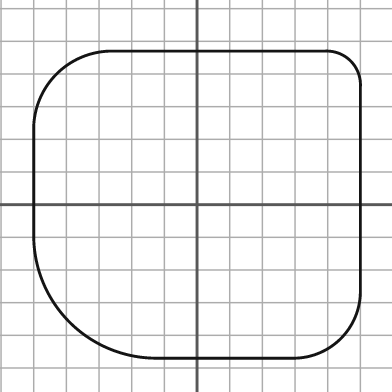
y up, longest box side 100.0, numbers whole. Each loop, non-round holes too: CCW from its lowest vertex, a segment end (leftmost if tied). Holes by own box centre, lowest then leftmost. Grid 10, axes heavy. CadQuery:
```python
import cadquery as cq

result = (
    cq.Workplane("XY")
    .moveTo(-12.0, -47.0)
    .lineTo(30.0, -47.0)
    .threePointArc((44.0, -41.0), (50.0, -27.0))
    .lineTo(50.0, 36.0)
    .threePointArc((47.0, 44.0), (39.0, 47.0))
    .lineTo(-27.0, 47.0)
    .threePointArc((-43.0, 40.0), (-50.0, 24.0))
    .lineTo(-50.0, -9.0)
    .threePointArc((-39.0, -36.0), (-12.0, -47.0))
    .close()
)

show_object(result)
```